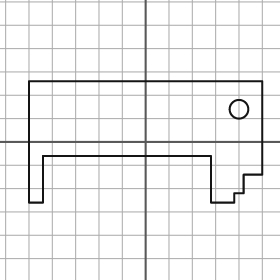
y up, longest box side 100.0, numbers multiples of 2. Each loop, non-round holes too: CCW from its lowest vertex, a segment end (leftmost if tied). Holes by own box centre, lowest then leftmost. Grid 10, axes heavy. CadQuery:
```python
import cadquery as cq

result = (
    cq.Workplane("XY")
    .moveTo(-50.0, -26.0)
    .lineTo(-44.0, -26.0)
    .lineTo(-44.0, -6.0)
    .lineTo(28.0, -6.0)
    .lineTo(28.0, -26.0)
    .lineTo(38.0, -26.0)
    .lineTo(38.0, -22.0)
    .lineTo(42.0, -22.0)
    .lineTo(42.0, -14.0)
    .lineTo(50.0, -14.0)
    .lineTo(50.0, 26.0)
    .lineTo(-50.0, 26.0)
    .close()
    .moveTo(40.0, 14.0)
    .circle(4.0)
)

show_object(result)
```